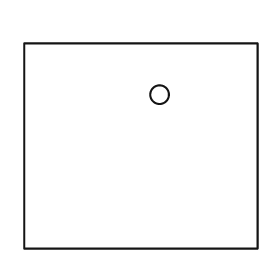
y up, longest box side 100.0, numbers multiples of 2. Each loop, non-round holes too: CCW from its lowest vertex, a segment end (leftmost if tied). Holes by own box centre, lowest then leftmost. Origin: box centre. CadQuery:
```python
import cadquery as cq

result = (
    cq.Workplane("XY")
    .moveTo(-50.0, -44.0)
    .lineTo(50.0, -44.0)
    .lineTo(50.0, 44.0)
    .lineTo(-50.0, 44.0)
    .close()
    .moveTo(8.0, 22.0)
    .circle(4.0)
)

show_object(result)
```